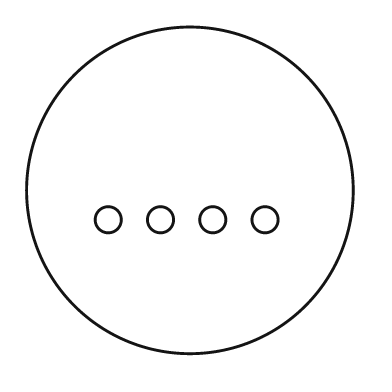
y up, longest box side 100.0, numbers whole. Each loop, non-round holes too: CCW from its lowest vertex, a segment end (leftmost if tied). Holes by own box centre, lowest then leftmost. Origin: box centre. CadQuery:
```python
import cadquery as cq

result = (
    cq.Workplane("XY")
    .moveTo(0.0, 0.0)
    .circle(50.0)
    .moveTo(-25.0, -9.0)
    .circle(4.0)
    .moveTo(-9.0, -9.0)
    .circle(4.0)
    .moveTo(7.0, -9.0)
    .circle(4.0)
    .moveTo(23.0, -9.0)
    .circle(4.0)
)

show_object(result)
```